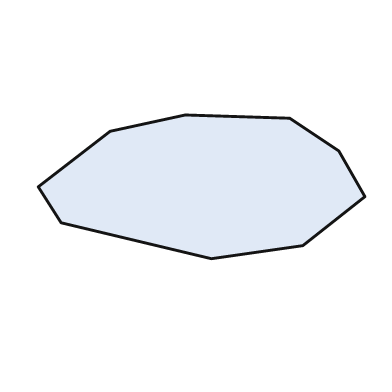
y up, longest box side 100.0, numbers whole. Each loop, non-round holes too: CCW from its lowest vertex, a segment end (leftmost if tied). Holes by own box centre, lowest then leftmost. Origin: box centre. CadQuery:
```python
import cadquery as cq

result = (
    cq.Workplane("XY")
    .moveTo(3.0, -22.0)
    .lineTo(31.0, -18.0)
    .lineTo(50.0, -3.0)
    .lineTo(42.0, 11.0)
    .lineTo(27.0, 21.0)
    .lineTo(-5.0, 22.0)
    .lineTo(-28.0, 17.0)
    .lineTo(-50.0, 0.0)
    .lineTo(-43.0, -11.0)
    .close()
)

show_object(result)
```